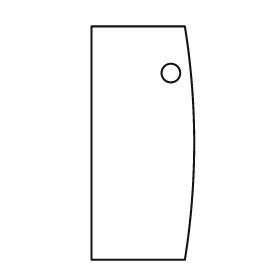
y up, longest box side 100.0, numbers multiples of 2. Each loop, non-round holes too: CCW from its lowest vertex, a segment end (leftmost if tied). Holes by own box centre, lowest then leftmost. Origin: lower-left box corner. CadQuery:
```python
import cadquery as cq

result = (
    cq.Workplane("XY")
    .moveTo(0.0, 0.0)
    .lineTo(40.0, 0.0)
    .threePointArc((44.0, 50.0), (40.0, 100.0))
    .lineTo(0.0, 100.0)
    .close()
    .moveTo(34.0, 80.0)
    .circle(4.0)
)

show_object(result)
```